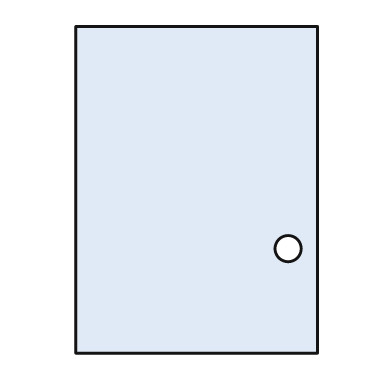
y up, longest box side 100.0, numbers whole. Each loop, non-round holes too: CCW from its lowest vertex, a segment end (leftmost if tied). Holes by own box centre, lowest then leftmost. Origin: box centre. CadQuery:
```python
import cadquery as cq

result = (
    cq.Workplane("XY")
    .moveTo(-37.0, -50.0)
    .lineTo(37.0, -50.0)
    .lineTo(37.0, 50.0)
    .lineTo(-37.0, 50.0)
    .close()
    .moveTo(28.0, -18.0)
    .circle(4.0)
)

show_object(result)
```